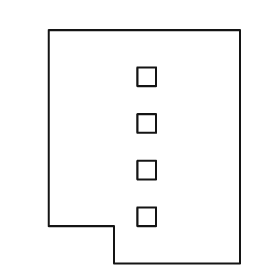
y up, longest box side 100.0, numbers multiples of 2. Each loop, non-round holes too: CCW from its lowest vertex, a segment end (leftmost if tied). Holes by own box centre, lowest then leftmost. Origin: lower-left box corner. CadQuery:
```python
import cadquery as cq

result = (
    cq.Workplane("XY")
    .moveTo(28.0, 0.0)
    .lineTo(82.0, 0.0)
    .lineTo(82.0, 100.0)
    .lineTo(0.0, 100.0)
    .lineTo(0.0, 16.0)
    .lineTo(28.0, 16.0)
    .close()
    .moveTo(38.0, 16.0)
    .lineTo(46.0, 16.0)
    .lineTo(46.0, 24.0)
    .lineTo(38.0, 24.0)
    .close()
    .moveTo(38.0, 36.0)
    .lineTo(46.0, 36.0)
    .lineTo(46.0, 44.0)
    .lineTo(38.0, 44.0)
    .close()
    .moveTo(38.0, 56.0)
    .lineTo(46.0, 56.0)
    .lineTo(46.0, 64.0)
    .lineTo(38.0, 64.0)
    .close()
    .moveTo(38.0, 76.0)
    .lineTo(46.0, 76.0)
    .lineTo(46.0, 84.0)
    .lineTo(38.0, 84.0)
    .close()
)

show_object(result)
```